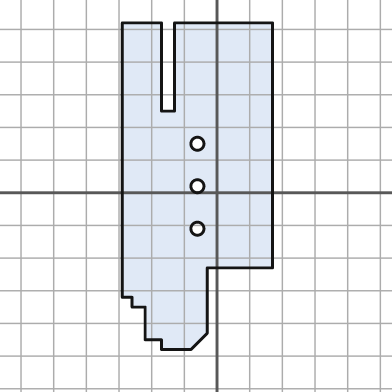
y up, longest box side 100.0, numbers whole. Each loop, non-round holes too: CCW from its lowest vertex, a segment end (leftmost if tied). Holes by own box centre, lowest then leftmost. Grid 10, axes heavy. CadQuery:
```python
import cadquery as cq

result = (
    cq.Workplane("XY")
    .moveTo(-17.0, -48.0)
    .lineTo(-8.0, -48.0)
    .lineTo(-3.0, -43.0)
    .lineTo(-3.0, -23.0)
    .lineTo(17.0, -23.0)
    .lineTo(17.0, 52.0)
    .lineTo(-13.0, 52.0)
    .lineTo(-13.0, 25.0)
    .lineTo(-17.0, 25.0)
    .lineTo(-17.0, 52.0)
    .lineTo(-29.0, 52.0)
    .lineTo(-29.0, -32.0)
    .lineTo(-26.0, -32.0)
    .lineTo(-26.0, -35.0)
    .lineTo(-22.0, -35.0)
    .lineTo(-22.0, -45.0)
    .lineTo(-17.0, -45.0)
    .close()
    .moveTo(-6.0, -11.0)
    .circle(2.0)
    .moveTo(-6.0, 2.0)
    .circle(2.0)
    .moveTo(-6.0, 15.0)
    .circle(2.0)
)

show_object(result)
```